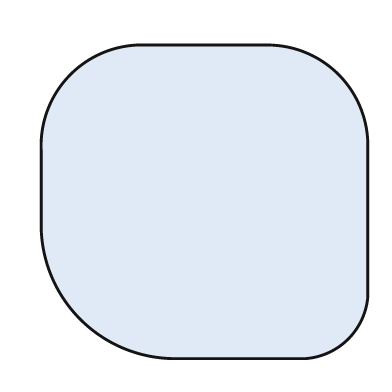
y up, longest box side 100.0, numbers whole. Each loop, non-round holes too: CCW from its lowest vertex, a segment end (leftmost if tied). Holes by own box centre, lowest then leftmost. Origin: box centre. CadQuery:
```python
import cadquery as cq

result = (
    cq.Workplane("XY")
    .moveTo(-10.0, -48.0)
    .lineTo(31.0, -48.0)
    .threePointArc((44.0, -42.0), (50.0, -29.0))
    .lineTo(50.0, 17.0)
    .threePointArc((41.0, 39.0), (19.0, 48.0))
    .lineTo(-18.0, 48.0)
    .threePointArc((-41.0, 39.0), (-50.0, 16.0))
    .lineTo(-50.0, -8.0)
    .threePointArc((-38.0, -36.0), (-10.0, -48.0))
    .close()
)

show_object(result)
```